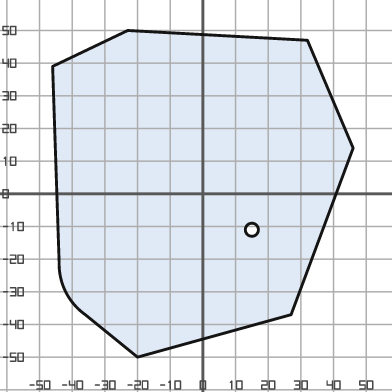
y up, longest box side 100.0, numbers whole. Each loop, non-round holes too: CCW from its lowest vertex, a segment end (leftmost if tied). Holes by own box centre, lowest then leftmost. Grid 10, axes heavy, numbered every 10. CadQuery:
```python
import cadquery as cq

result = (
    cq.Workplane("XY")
    .moveTo(-20.0, -50.0)
    .lineTo(27.0, -37.0)
    .lineTo(46.0, 14.0)
    .lineTo(32.0, 47.0)
    .lineTo(-23.0, 50.0)
    .lineTo(-46.0, 39.0)
    .lineTo(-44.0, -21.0)
    .threePointArc((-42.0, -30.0), (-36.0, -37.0))
    .close()
    .moveTo(15.0, -11.0)
    .circle(2.0)
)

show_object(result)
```